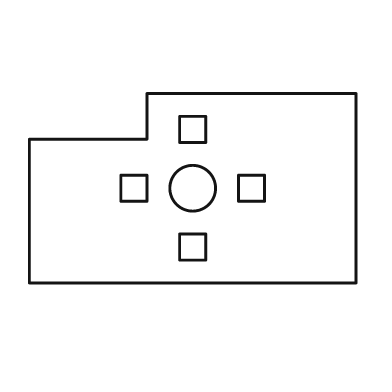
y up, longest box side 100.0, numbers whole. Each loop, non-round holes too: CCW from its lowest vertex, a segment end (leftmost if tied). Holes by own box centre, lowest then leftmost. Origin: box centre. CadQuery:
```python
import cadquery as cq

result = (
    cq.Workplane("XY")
    .moveTo(-50.0, -29.0)
    .lineTo(50.0, -29.0)
    .lineTo(50.0, 29.0)
    .lineTo(-14.0, 29.0)
    .lineTo(-14.0, 15.0)
    .lineTo(-50.0, 15.0)
    .close()
    .moveTo(-4.0, -22.0)
    .lineTo(4.0, -22.0)
    .lineTo(4.0, -14.0)
    .lineTo(-4.0, -14.0)
    .close()
    .moveTo(-22.0, -4.0)
    .lineTo(-14.0, -4.0)
    .lineTo(-14.0, 4.0)
    .lineTo(-22.0, 4.0)
    .close()
    .moveTo(0.0, 0.0)
    .circle(7.0)
    .moveTo(14.0, -4.0)
    .lineTo(22.0, -4.0)
    .lineTo(22.0, 4.0)
    .lineTo(14.0, 4.0)
    .close()
    .moveTo(-4.0, 14.0)
    .lineTo(4.0, 14.0)
    .lineTo(4.0, 22.0)
    .lineTo(-4.0, 22.0)
    .close()
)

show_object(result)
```